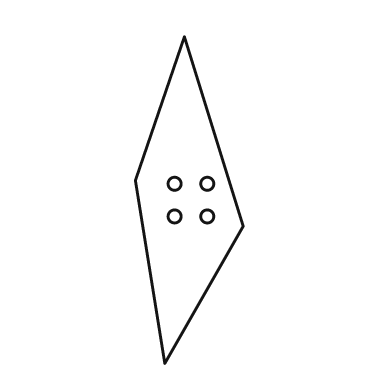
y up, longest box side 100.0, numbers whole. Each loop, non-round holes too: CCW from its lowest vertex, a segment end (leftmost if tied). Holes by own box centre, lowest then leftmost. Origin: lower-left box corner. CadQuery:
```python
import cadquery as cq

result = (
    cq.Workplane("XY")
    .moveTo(9.0, 0.0)
    .lineTo(33.0, 42.0)
    .lineTo(15.0, 100.0)
    .lineTo(0.0, 56.0)
    .close()
    .moveTo(12.0, 45.0)
    .circle(2.0)
    .moveTo(22.0, 45.0)
    .circle(2.0)
    .moveTo(12.0, 55.0)
    .circle(2.0)
    .moveTo(22.0, 55.0)
    .circle(2.0)
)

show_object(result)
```